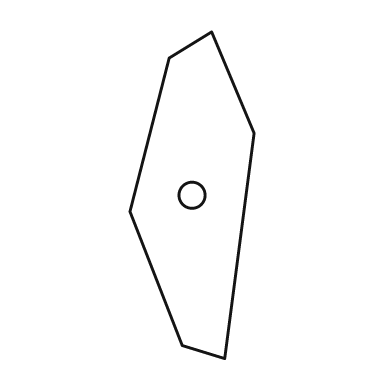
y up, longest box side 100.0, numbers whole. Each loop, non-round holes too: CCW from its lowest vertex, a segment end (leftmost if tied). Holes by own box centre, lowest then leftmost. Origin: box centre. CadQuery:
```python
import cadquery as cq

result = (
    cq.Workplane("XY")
    .moveTo(10.0, -50.0)
    .lineTo(19.0, 19.0)
    .lineTo(6.0, 50.0)
    .lineTo(-7.0, 42.0)
    .lineTo(-19.0, -5.0)
    .lineTo(-3.0, -46.0)
    .close()
    .moveTo(0.0, 0.0)
    .circle(4.0)
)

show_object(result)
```